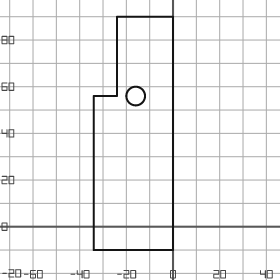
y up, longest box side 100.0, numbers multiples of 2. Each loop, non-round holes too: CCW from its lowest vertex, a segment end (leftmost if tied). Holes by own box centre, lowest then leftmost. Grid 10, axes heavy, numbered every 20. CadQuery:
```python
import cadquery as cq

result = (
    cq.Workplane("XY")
    .moveTo(-34.0, -10.0)
    .lineTo(0.0, -10.0)
    .lineTo(0.0, 90.0)
    .lineTo(-24.0, 90.0)
    .lineTo(-24.0, 56.0)
    .lineTo(-34.0, 56.0)
    .close()
    .moveTo(-16.0, 56.0)
    .circle(4.0)
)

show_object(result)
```